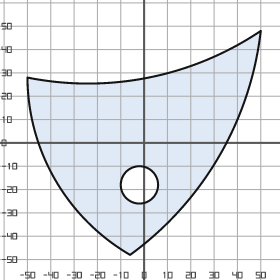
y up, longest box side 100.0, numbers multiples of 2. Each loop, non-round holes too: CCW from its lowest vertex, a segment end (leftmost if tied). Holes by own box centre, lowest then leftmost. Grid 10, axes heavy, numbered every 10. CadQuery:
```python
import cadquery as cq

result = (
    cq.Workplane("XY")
    .moveTo(-6.0, -48.0)
    .threePointArc((32.0, -6.0), (50.0, 48.0))
    .threePointArc((2.0, 28.0), (-50.0, 28.0))
    .threePointArc((-38.0, -16.0), (-6.0, -48.0))
    .close()
    .moveTo(-2.0, -18.0)
    .circle(8.0)
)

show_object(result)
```